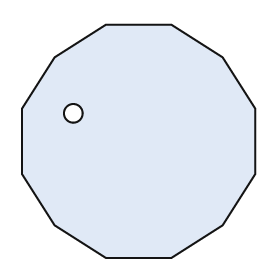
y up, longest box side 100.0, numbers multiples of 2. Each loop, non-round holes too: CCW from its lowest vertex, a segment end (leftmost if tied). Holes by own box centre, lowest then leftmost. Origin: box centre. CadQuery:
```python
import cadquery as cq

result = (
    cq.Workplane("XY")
    .moveTo(-14.0, -50.0)
    .lineTo(14.0, -50.0)
    .lineTo(36.0, -36.0)
    .lineTo(50.0, -14.0)
    .lineTo(50.0, 14.0)
    .lineTo(36.0, 36.0)
    .lineTo(14.0, 50.0)
    .lineTo(-14.0, 50.0)
    .lineTo(-36.0, 36.0)
    .lineTo(-50.0, 14.0)
    .lineTo(-50.0, -14.0)
    .lineTo(-36.0, -36.0)
    .close()
    .moveTo(-28.0, 12.0)
    .circle(4.0)
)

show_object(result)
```